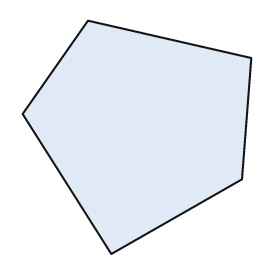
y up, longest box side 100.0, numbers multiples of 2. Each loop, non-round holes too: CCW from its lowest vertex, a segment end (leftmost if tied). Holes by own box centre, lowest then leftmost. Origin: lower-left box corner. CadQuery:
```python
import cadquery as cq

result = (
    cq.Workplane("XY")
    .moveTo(38.0, 0.0)
    .lineTo(94.0, 32.0)
    .lineTo(98.0, 84.0)
    .lineTo(28.0, 100.0)
    .lineTo(0.0, 60.0)
    .close()
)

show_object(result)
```